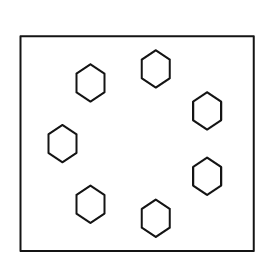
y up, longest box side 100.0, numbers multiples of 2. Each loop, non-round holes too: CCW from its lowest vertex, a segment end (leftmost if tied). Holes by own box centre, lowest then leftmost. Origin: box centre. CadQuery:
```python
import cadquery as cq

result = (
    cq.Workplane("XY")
    .moveTo(-50.0, -46.0)
    .lineTo(50.0, -46.0)
    .lineTo(50.0, 46.0)
    .lineTo(-50.0, 46.0)
    .close()
    .moveTo(8.0, -40.0)
    .lineTo(14.0, -36.0)
    .lineTo(14.0, -28.0)
    .lineTo(8.0, -24.0)
    .lineTo(2.0, -28.0)
    .lineTo(2.0, -36.0)
    .close()
    .moveTo(-20.0, -34.0)
    .lineTo(-14.0, -30.0)
    .lineTo(-14.0, -22.0)
    .lineTo(-20.0, -18.0)
    .lineTo(-26.0, -22.0)
    .lineTo(-26.0, -30.0)
    .close()
    .moveTo(30.0, -22.0)
    .lineTo(36.0, -18.0)
    .lineTo(36.0, -10.0)
    .lineTo(30.0, -6.0)
    .lineTo(24.0, -10.0)
    .lineTo(24.0, -18.0)
    .close()
    .moveTo(-32.0, -8.0)
    .lineTo(-26.0, -4.0)
    .lineTo(-26.0, 4.0)
    .lineTo(-32.0, 8.0)
    .lineTo(-38.0, 4.0)
    .lineTo(-38.0, -4.0)
    .close()
    .moveTo(30.0, 6.0)
    .lineTo(36.0, 10.0)
    .lineTo(36.0, 18.0)
    .lineTo(30.0, 22.0)
    .lineTo(24.0, 18.0)
    .lineTo(24.0, 10.0)
    .close()
    .moveTo(-20.0, 18.0)
    .lineTo(-14.0, 22.0)
    .lineTo(-14.0, 30.0)
    .lineTo(-20.0, 34.0)
    .lineTo(-26.0, 30.0)
    .lineTo(-26.0, 22.0)
    .close()
    .moveTo(8.0, 24.0)
    .lineTo(14.0, 28.0)
    .lineTo(14.0, 36.0)
    .lineTo(8.0, 40.0)
    .lineTo(2.0, 36.0)
    .lineTo(2.0, 28.0)
    .close()
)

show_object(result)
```